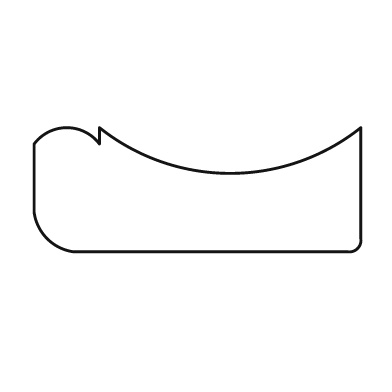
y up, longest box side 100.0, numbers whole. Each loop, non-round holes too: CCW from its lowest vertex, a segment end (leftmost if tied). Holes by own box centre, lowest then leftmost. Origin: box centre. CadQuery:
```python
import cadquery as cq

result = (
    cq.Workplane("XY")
    .moveTo(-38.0, -19.0)
    .lineTo(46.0, -19.0)
    .threePointArc((49.0, -18.0), (50.0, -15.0))
    .lineTo(50.0, 19.0)
    .threePointArc((10.0, 5.0), (-30.0, 19.0))
    .lineTo(-30.0, 14.0)
    .threePointArc((-40.0, 19.0), (-50.0, 14.0))
    .lineTo(-50.0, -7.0)
    .threePointArc((-46.0, -15.0), (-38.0, -19.0))
    .close()
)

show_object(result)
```